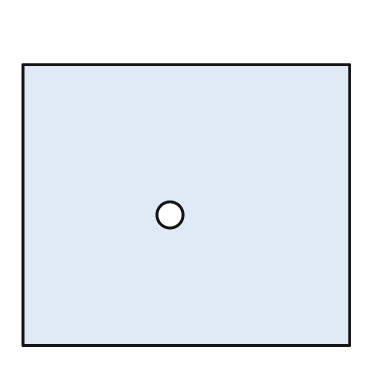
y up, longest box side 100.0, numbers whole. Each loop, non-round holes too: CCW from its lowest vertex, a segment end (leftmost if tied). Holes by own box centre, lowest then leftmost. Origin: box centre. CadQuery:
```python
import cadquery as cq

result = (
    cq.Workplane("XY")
    .moveTo(-50.0, -43.0)
    .lineTo(50.0, -43.0)
    .lineTo(50.0, 43.0)
    .lineTo(-50.0, 43.0)
    .close()
    .moveTo(-5.0, -3.0)
    .circle(4.0)
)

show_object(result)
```